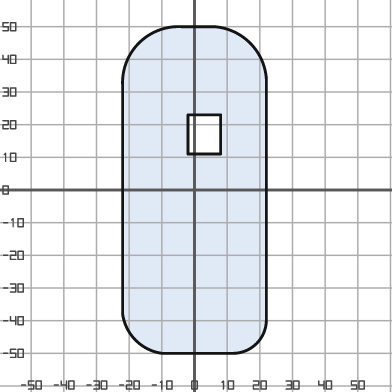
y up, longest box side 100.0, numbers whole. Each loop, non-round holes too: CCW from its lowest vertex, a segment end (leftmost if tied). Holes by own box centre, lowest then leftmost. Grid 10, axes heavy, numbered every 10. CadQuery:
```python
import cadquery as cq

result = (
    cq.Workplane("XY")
    .moveTo(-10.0, -50.0)
    .lineTo(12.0, -50.0)
    .threePointArc((19.0, -47.0), (22.0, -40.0))
    .lineTo(22.0, 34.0)
    .threePointArc((17.0, 45.0), (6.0, 50.0))
    .lineTo(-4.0, 50.0)
    .threePointArc((-17.0, 45.0), (-22.0, 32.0))
    .lineTo(-22.0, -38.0)
    .threePointArc((-18.0, -46.0), (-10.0, -50.0))
    .close()
    .moveTo(-2.0, 11.0)
    .lineTo(8.0, 11.0)
    .lineTo(8.0, 23.0)
    .lineTo(-2.0, 23.0)
    .close()
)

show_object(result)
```